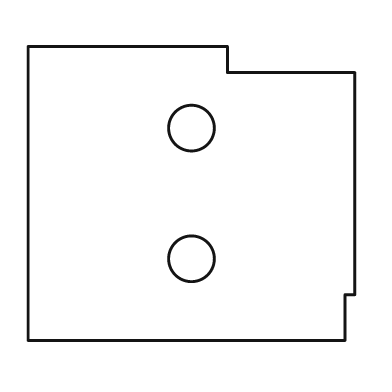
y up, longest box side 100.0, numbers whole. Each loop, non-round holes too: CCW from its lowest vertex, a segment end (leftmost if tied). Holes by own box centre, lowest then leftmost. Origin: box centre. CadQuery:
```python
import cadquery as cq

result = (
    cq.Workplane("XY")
    .moveTo(-50.0, -45.0)
    .lineTo(47.0, -45.0)
    .lineTo(47.0, -31.0)
    .lineTo(50.0, -31.0)
    .lineTo(50.0, 37.0)
    .lineTo(11.0, 37.0)
    .lineTo(11.0, 45.0)
    .lineTo(-50.0, 45.0)
    .close()
    .moveTo(0.0, -20.0)
    .circle(7.0)
    .moveTo(0.0, 20.0)
    .circle(7.0)
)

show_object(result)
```